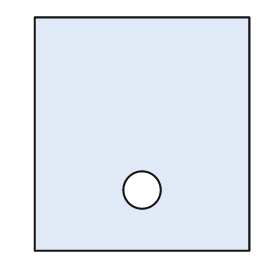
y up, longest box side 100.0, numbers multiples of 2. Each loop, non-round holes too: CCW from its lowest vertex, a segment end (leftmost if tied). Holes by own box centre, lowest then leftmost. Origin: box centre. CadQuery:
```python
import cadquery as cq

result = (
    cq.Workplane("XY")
    .moveTo(-46.0, -50.0)
    .lineTo(46.0, -50.0)
    .lineTo(46.0, 50.0)
    .lineTo(-46.0, 50.0)
    .close()
    .moveTo(0.0, -24.0)
    .circle(8.0)
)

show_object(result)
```